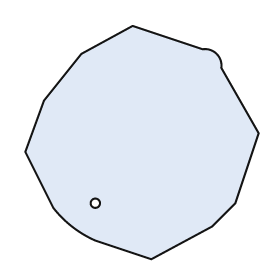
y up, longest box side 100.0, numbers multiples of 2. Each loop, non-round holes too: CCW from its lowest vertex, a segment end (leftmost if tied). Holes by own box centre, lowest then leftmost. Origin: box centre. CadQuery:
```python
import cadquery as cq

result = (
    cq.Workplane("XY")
    .moveTo(4.0, -50.0)
    .lineTo(30.0, -36.0)
    .lineTo(40.0, -26.0)
    .lineTo(50.0, 4.0)
    .lineTo(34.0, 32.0)
    .threePointArc((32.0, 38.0), (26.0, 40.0))
    .lineTo(-4.0, 50.0)
    .lineTo(-26.0, 38.0)
    .lineTo(-42.0, 18.0)
    .lineTo(-50.0, -4.0)
    .lineTo(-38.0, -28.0)
    .threePointArc((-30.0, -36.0), (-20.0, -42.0))
    .close()
    .moveTo(-20.0, -26.0)
    .circle(2.0)
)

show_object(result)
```